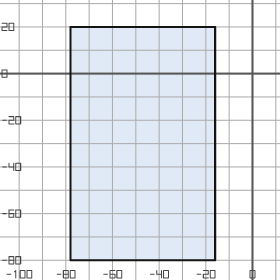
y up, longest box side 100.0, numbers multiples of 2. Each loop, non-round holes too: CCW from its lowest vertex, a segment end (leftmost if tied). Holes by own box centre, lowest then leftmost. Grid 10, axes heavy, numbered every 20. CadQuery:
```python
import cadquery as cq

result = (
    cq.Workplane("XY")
    .moveTo(-78.0, -80.0)
    .lineTo(-16.0, -80.0)
    .lineTo(-16.0, 20.0)
    .lineTo(-78.0, 20.0)
    .close()
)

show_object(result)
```